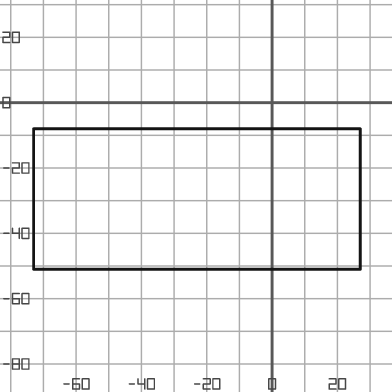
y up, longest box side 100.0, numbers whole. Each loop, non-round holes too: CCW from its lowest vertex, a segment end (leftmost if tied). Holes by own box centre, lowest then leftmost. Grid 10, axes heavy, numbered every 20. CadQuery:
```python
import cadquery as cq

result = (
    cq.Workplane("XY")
    .moveTo(-73.0, -51.0)
    .lineTo(27.0, -51.0)
    .lineTo(27.0, -8.0)
    .lineTo(-73.0, -8.0)
    .close()
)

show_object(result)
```